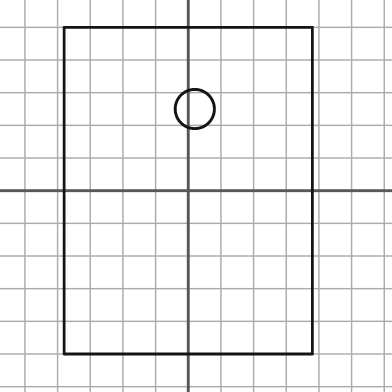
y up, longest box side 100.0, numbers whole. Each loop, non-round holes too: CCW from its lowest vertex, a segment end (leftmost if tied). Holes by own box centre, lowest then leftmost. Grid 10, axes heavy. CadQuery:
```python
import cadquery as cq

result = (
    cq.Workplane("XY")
    .moveTo(-38.0, -50.0)
    .lineTo(38.0, -50.0)
    .lineTo(38.0, 50.0)
    .lineTo(-38.0, 50.0)
    .close()
    .moveTo(2.0, 25.0)
    .circle(6.0)
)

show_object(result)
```